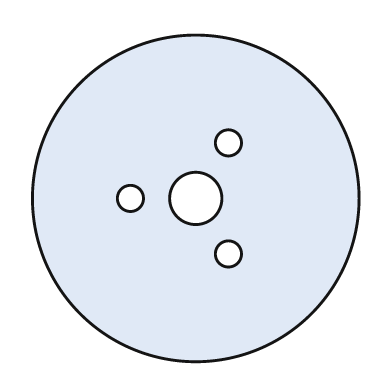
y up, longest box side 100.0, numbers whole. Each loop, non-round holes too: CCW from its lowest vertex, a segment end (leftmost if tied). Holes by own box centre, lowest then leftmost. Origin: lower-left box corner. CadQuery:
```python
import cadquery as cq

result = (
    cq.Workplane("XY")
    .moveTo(50.0, 50.0)
    .circle(50.0)
    .moveTo(60.0, 33.0)
    .circle(4.0)
    .moveTo(30.0, 50.0)
    .circle(4.0)
    .moveTo(50.0, 50.0)
    .circle(8.0)
    .moveTo(60.0, 67.0)
    .circle(4.0)
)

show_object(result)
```